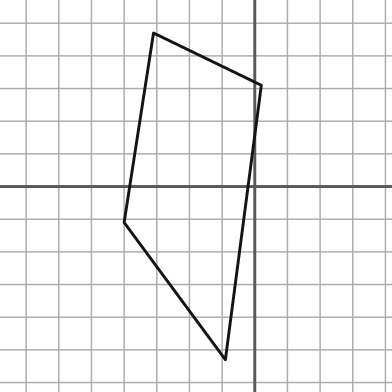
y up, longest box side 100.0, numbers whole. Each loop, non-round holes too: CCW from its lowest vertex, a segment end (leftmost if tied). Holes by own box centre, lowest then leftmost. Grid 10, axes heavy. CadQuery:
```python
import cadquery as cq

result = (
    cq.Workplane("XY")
    .moveTo(-9.0, -53.0)
    .lineTo(2.0, 31.0)
    .lineTo(-31.0, 47.0)
    .lineTo(-40.0, -11.0)
    .close()
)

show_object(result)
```